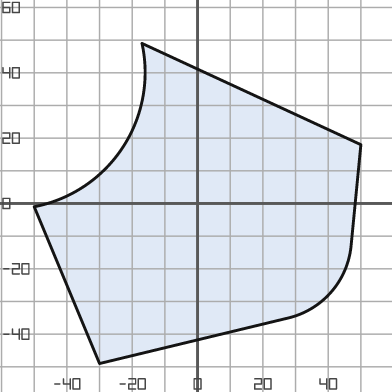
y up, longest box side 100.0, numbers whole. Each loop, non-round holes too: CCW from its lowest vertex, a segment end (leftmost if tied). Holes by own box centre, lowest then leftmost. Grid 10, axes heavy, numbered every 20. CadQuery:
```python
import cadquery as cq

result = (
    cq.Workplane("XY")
    .moveTo(-30.0, -49.0)
    .lineTo(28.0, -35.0)
    .threePointArc((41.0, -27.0), (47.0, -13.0))
    .lineTo(50.0, 18.0)
    .lineTo(-17.0, 49.0)
    .threePointArc((-23.0, 17.0), (-50.0, -1.0))
    .close()
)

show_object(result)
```